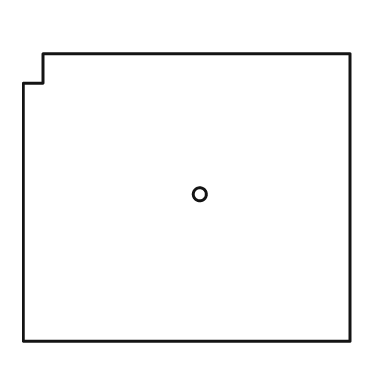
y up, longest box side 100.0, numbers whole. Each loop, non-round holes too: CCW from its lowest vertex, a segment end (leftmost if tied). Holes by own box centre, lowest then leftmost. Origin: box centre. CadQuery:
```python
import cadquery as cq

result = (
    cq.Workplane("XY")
    .moveTo(-50.0, -44.0)
    .lineTo(50.0, -44.0)
    .lineTo(50.0, 44.0)
    .lineTo(-44.0, 44.0)
    .lineTo(-44.0, 35.0)
    .lineTo(-50.0, 35.0)
    .close()
    .moveTo(4.0, 1.0)
    .circle(2.0)
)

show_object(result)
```